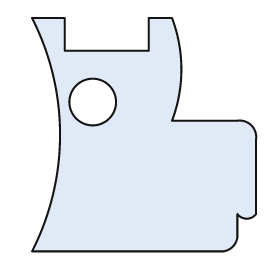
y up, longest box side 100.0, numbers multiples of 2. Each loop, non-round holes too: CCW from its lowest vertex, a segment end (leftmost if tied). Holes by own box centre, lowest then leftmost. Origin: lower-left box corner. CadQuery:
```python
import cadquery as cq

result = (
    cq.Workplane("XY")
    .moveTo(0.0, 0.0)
    .lineTo(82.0, 0.0)
    .threePointArc((86.0, 2.0), (88.0, 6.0))
    .lineTo(88.0, 16.0)
    .threePointArc((92.0, 14.0), (96.0, 16.0))
    .lineTo(96.0, 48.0)
    .threePointArc((94.0, 54.0), (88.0, 56.0))
    .lineTo(60.0, 56.0)
    .threePointArc((64.0, 78.0), (60.0, 100.0))
    .lineTo(50.0, 100.0)
    .lineTo(50.0, 86.0)
    .lineTo(14.0, 86.0)
    .lineTo(14.0, 100.0)
    .lineTo(0.0, 100.0)
    .threePointArc((12.0, 50.0), (0.0, 0.0))
    .close()
    .moveTo(26.0, 64.0)
    .circle(10.0)
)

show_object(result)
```